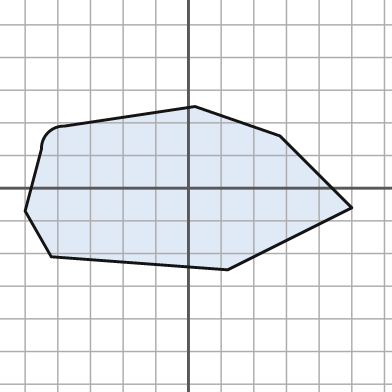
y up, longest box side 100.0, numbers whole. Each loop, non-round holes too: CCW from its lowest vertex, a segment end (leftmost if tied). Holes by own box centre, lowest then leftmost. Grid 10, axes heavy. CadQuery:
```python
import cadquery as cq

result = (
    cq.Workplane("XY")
    .moveTo(12.0, -25.0)
    .lineTo(50.0, -6.0)
    .lineTo(28.0, 16.0)
    .lineTo(2.0, 25.0)
    .lineTo(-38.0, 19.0)
    .threePointArc((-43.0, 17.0), (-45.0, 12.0))
    .lineTo(-50.0, -7.0)
    .lineTo(-42.0, -21.0)
    .close()
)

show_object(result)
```